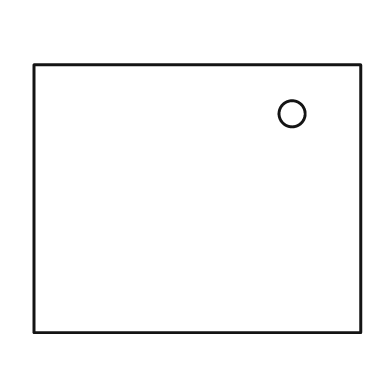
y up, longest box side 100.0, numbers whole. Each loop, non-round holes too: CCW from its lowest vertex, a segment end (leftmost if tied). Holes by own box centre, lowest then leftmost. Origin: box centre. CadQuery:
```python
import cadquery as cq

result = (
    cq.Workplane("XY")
    .moveTo(-50.0, -41.0)
    .lineTo(50.0, -41.0)
    .lineTo(50.0, 41.0)
    .lineTo(-50.0, 41.0)
    .close()
    .moveTo(29.0, 26.0)
    .circle(4.0)
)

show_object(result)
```